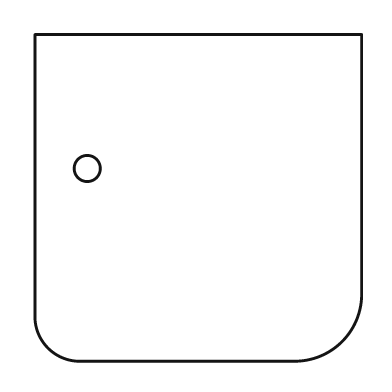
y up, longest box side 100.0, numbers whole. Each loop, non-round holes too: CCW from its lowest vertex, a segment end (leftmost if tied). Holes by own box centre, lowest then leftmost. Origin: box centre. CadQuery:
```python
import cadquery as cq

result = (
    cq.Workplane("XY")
    .moveTo(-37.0, -50.0)
    .lineTo(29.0, -50.0)
    .threePointArc((44.0, -44.0), (50.0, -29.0))
    .lineTo(50.0, 50.0)
    .lineTo(-50.0, 50.0)
    .lineTo(-50.0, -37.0)
    .threePointArc((-46.0, -46.0), (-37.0, -50.0))
    .close()
    .moveTo(-34.0, 9.0)
    .circle(4.0)
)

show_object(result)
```